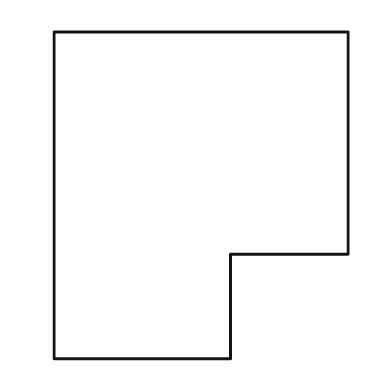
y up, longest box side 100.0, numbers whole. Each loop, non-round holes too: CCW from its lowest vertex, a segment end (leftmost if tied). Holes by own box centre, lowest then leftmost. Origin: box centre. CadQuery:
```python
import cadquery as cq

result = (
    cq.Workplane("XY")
    .moveTo(-45.0, -50.0)
    .lineTo(9.0, -50.0)
    .lineTo(9.0, -18.0)
    .lineTo(45.0, -18.0)
    .lineTo(45.0, 50.0)
    .lineTo(-45.0, 50.0)
    .close()
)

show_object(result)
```